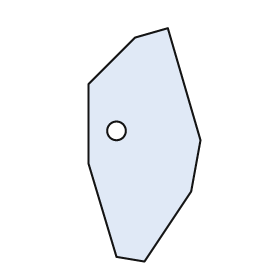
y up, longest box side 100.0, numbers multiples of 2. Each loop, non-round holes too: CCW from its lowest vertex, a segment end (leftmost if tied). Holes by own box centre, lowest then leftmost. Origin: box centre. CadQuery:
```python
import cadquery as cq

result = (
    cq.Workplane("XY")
    .moveTo(0.0, -50.0)
    .lineTo(20.0, -20.0)
    .lineTo(24.0, 2.0)
    .lineTo(10.0, 50.0)
    .lineTo(-4.0, 46.0)
    .lineTo(-24.0, 26.0)
    .lineTo(-24.0, -8.0)
    .lineTo(-12.0, -48.0)
    .close()
    .moveTo(-12.0, 6.0)
    .circle(4.0)
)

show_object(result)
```